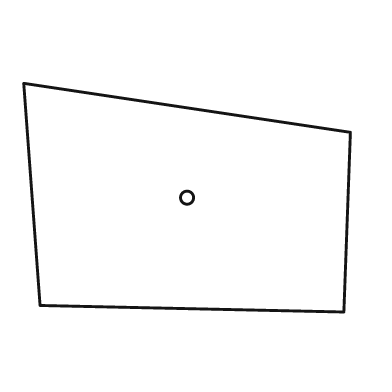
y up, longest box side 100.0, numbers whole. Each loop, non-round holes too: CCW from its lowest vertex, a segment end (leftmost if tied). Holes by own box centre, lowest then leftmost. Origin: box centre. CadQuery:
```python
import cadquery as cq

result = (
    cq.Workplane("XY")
    .moveTo(48.0, -35.0)
    .lineTo(50.0, 20.0)
    .lineTo(-50.0, 35.0)
    .lineTo(-45.0, -33.0)
    .close()
    .moveTo(0.0, 0.0)
    .circle(2.0)
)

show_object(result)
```